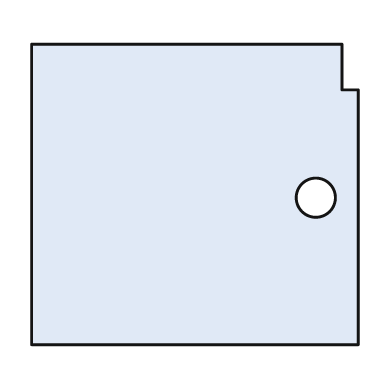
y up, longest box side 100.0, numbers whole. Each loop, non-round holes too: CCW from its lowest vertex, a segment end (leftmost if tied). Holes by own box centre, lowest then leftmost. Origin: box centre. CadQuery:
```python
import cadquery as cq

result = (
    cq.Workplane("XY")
    .moveTo(-50.0, -46.0)
    .lineTo(50.0, -46.0)
    .lineTo(50.0, 32.0)
    .lineTo(45.0, 32.0)
    .lineTo(45.0, 46.0)
    .lineTo(-50.0, 46.0)
    .close()
    .moveTo(37.0, -1.0)
    .circle(6.0)
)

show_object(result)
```